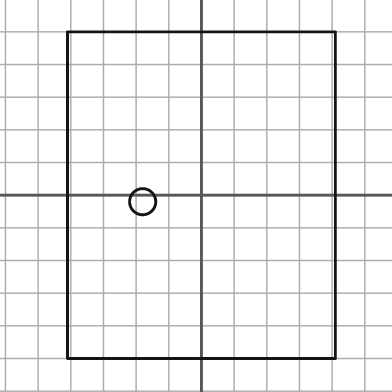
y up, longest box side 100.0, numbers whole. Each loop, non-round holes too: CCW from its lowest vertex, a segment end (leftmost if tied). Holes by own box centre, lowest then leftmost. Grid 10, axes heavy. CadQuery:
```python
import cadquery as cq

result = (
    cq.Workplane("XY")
    .moveTo(-41.0, -50.0)
    .lineTo(41.0, -50.0)
    .lineTo(41.0, 50.0)
    .lineTo(-41.0, 50.0)
    .close()
    .moveTo(-18.0, -2.0)
    .circle(4.0)
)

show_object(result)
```